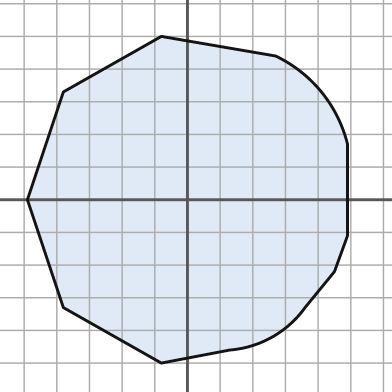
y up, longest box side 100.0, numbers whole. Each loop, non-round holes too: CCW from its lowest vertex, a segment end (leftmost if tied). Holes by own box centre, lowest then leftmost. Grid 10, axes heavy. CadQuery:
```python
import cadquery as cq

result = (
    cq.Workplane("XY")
    .moveTo(-8.0, -50.0)
    .lineTo(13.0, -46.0)
    .threePointArc((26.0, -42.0), (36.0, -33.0))
    .lineTo(45.0, -22.0)
    .lineTo(49.0, -11.0)
    .lineTo(49.0, 17.0)
    .threePointArc((41.0, 33.0), (27.0, 44.0))
    .lineTo(-8.0, 50.0)
    .lineTo(-38.0, 33.0)
    .lineTo(-49.0, 0.0)
    .lineTo(-38.0, -33.0)
    .close()
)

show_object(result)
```